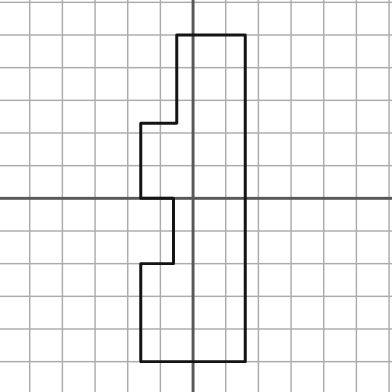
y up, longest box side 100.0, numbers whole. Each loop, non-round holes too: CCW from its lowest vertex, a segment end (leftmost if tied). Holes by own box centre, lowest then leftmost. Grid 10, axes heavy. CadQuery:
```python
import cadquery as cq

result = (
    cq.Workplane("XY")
    .moveTo(-16.0, -50.0)
    .lineTo(16.0, -50.0)
    .lineTo(16.0, 50.0)
    .lineTo(-5.0, 50.0)
    .lineTo(-5.0, 23.0)
    .lineTo(-16.0, 23.0)
    .lineTo(-16.0, 0.0)
    .lineTo(-6.0, 0.0)
    .lineTo(-6.0, -20.0)
    .lineTo(-16.0, -20.0)
    .close()
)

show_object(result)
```